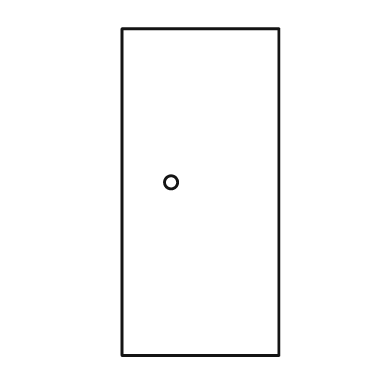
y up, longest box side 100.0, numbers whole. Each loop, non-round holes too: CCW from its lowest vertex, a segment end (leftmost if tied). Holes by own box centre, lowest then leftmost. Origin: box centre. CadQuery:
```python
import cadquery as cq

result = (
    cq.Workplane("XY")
    .moveTo(-24.0, -50.0)
    .lineTo(24.0, -50.0)
    .lineTo(24.0, 50.0)
    .lineTo(-24.0, 50.0)
    .close()
    .moveTo(-9.0, 3.0)
    .circle(2.0)
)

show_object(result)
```